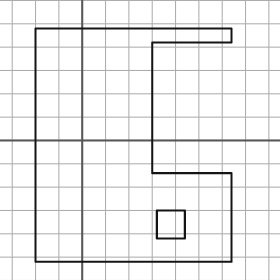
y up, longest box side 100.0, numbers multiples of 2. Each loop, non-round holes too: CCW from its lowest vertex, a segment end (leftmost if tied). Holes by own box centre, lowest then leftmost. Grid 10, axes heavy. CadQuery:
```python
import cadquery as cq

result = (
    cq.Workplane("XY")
    .moveTo(-20.0, -52.0)
    .lineTo(64.0, -52.0)
    .lineTo(64.0, -14.0)
    .lineTo(30.0, -14.0)
    .lineTo(30.0, 42.0)
    .lineTo(64.0, 42.0)
    .lineTo(64.0, 48.0)
    .lineTo(-20.0, 48.0)
    .close()
    .moveTo(32.0, -42.0)
    .lineTo(44.0, -42.0)
    .lineTo(44.0, -30.0)
    .lineTo(32.0, -30.0)
    .close()
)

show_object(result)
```